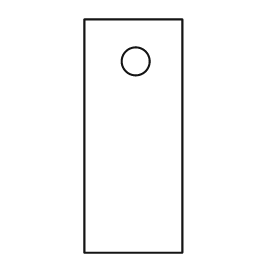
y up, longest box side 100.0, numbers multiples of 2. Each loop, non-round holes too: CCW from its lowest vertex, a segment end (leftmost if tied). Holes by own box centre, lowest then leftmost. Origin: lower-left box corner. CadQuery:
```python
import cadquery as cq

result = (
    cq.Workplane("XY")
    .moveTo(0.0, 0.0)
    .lineTo(42.0, 0.0)
    .lineTo(42.0, 100.0)
    .lineTo(0.0, 100.0)
    .close()
    .moveTo(22.0, 82.0)
    .circle(6.0)
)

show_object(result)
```